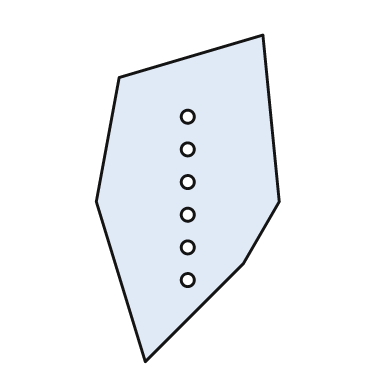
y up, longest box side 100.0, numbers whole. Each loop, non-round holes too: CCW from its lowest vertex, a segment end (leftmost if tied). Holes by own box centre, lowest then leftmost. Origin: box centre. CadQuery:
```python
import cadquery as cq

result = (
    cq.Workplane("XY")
    .moveTo(-13.0, -50.0)
    .lineTo(17.0, -20.0)
    .lineTo(28.0, -1.0)
    .lineTo(23.0, 50.0)
    .lineTo(-21.0, 37.0)
    .lineTo(-28.0, -1.0)
    .close()
    .moveTo(0.0, -25.0)
    .circle(2.0)
    .moveTo(0.0, -15.0)
    .circle(2.0)
    .moveTo(0.0, -5.0)
    .circle(2.0)
    .moveTo(0.0, 5.0)
    .circle(2.0)
    .moveTo(0.0, 15.0)
    .circle(2.0)
    .moveTo(0.0, 25.0)
    .circle(2.0)
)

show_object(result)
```